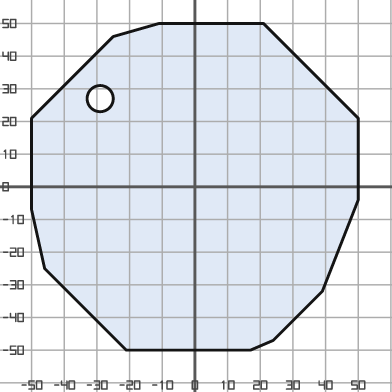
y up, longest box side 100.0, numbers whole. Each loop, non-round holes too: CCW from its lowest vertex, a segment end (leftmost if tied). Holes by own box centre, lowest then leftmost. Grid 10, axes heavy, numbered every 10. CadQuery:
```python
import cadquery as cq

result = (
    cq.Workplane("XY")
    .moveTo(-21.0, -50.0)
    .lineTo(17.0, -50.0)
    .lineTo(24.0, -47.0)
    .lineTo(39.0, -32.0)
    .lineTo(50.0, -4.0)
    .lineTo(50.0, 21.0)
    .lineTo(21.0, 50.0)
    .lineTo(-11.0, 50.0)
    .lineTo(-25.0, 46.0)
    .lineTo(-50.0, 21.0)
    .lineTo(-50.0, -7.0)
    .lineTo(-46.0, -25.0)
    .close()
    .moveTo(-29.0, 27.0)
    .circle(4.0)
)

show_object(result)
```